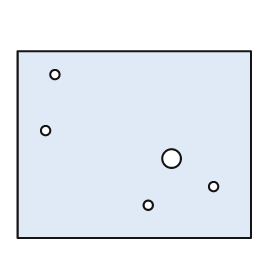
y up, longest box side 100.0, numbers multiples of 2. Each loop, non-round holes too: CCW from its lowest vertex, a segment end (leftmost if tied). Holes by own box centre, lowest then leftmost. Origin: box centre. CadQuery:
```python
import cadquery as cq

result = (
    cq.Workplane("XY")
    .moveTo(-50.0, -40.0)
    .lineTo(50.0, -40.0)
    .lineTo(50.0, 40.0)
    .lineTo(-50.0, 40.0)
    .close()
    .moveTo(6.0, -26.0)
    .circle(2.0)
    .moveTo(34.0, -18.0)
    .circle(2.0)
    .moveTo(16.0, -6.0)
    .circle(4.0)
    .moveTo(-38.0, 6.0)
    .circle(2.0)
    .moveTo(-34.0, 30.0)
    .circle(2.0)
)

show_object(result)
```